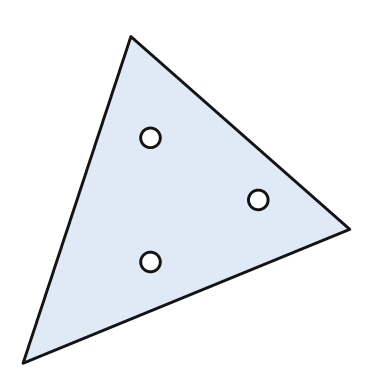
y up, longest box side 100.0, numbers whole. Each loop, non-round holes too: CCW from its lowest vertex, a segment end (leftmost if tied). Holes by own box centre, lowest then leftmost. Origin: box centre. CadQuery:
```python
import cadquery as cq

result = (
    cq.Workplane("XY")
    .moveTo(-50.0, -50.0)
    .lineTo(50.0, -9.0)
    .lineTo(-17.0, 50.0)
    .close()
    .moveTo(-11.0, -19.0)
    .circle(3.0)
    .moveTo(22.0, 0.0)
    .circle(3.0)
    .moveTo(-11.0, 19.0)
    .circle(3.0)
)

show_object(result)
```